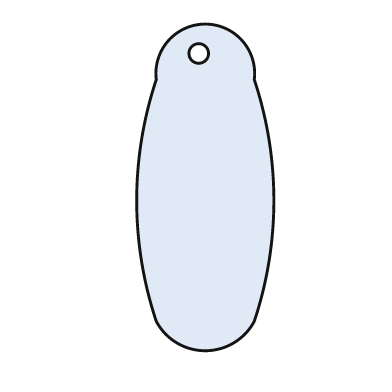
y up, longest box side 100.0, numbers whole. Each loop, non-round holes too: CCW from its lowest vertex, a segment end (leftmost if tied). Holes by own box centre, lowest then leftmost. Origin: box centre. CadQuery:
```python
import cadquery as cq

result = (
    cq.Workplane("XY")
    .moveTo(-15.0, -41.0)
    .threePointArc((0.0, -50.0), (15.0, -41.0))
    .threePointArc((21.0, -4.0), (15.0, 33.0))
    .threePointArc((0.0, 50.0), (-15.0, 33.0))
    .threePointArc((-21.0, -4.0), (-15.0, -41.0))
    .close()
    .moveTo(-2.0, 41.0)
    .circle(3.0)
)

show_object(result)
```